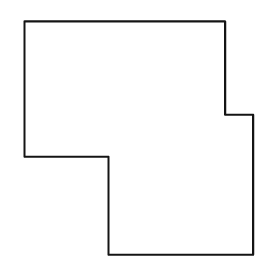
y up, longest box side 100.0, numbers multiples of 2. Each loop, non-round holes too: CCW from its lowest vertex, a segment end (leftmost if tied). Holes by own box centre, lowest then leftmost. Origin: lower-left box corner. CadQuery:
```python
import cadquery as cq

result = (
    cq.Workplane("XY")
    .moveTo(36.0, 0.0)
    .lineTo(98.0, 0.0)
    .lineTo(98.0, 60.0)
    .lineTo(86.0, 60.0)
    .lineTo(86.0, 100.0)
    .lineTo(0.0, 100.0)
    .lineTo(0.0, 42.0)
    .lineTo(36.0, 42.0)
    .close()
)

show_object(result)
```